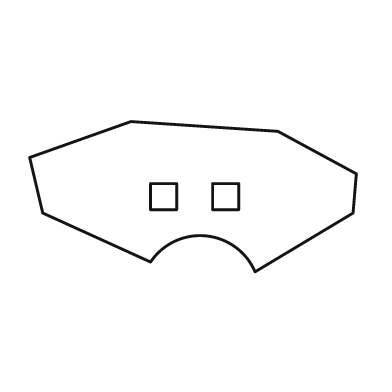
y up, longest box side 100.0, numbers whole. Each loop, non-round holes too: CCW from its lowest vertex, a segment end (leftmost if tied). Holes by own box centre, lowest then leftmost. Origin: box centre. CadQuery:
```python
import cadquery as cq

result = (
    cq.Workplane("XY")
    .moveTo(19.0, -23.0)
    .lineTo(49.0, -5.0)
    .lineTo(50.0, 7.0)
    .lineTo(26.0, 20.0)
    .lineTo(-19.0, 23.0)
    .lineTo(-50.0, 12.0)
    .lineTo(-46.0, -5.0)
    .lineTo(-13.0, -20.0)
    .threePointArc((4.0, -12.0), (19.0, -23.0))
    .close()
    .moveTo(-13.0, -4.0)
    .lineTo(-5.0, -4.0)
    .lineTo(-5.0, 4.0)
    .lineTo(-13.0, 4.0)
    .close()
    .moveTo(6.0, -4.0)
    .lineTo(14.0, -4.0)
    .lineTo(14.0, 4.0)
    .lineTo(6.0, 4.0)
    .close()
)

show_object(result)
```